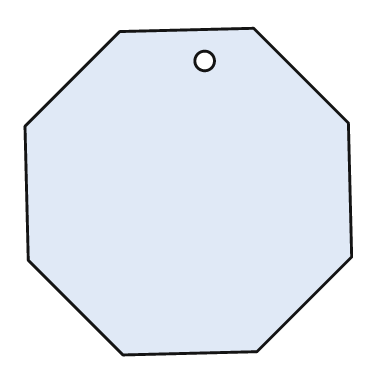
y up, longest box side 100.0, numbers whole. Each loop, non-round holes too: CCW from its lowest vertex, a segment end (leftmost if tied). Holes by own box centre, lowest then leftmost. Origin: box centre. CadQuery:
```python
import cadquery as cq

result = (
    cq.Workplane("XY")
    .moveTo(-20.0, -50.0)
    .lineTo(21.0, -49.0)
    .lineTo(50.0, -20.0)
    .lineTo(49.0, 21.0)
    .lineTo(20.0, 50.0)
    .lineTo(-21.0, 49.0)
    .lineTo(-50.0, 20.0)
    .lineTo(-49.0, -21.0)
    .close()
    .moveTo(5.0, 40.0)
    .circle(3.0)
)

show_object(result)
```